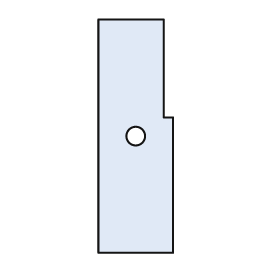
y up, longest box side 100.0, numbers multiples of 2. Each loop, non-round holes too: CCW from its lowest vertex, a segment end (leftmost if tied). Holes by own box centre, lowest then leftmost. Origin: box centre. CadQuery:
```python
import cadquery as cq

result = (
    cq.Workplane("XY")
    .moveTo(-16.0, -50.0)
    .lineTo(16.0, -50.0)
    .lineTo(16.0, 8.0)
    .lineTo(12.0, 8.0)
    .lineTo(12.0, 50.0)
    .lineTo(-16.0, 50.0)
    .close()
    .moveTo(0.0, 0.0)
    .circle(4.0)
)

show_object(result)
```